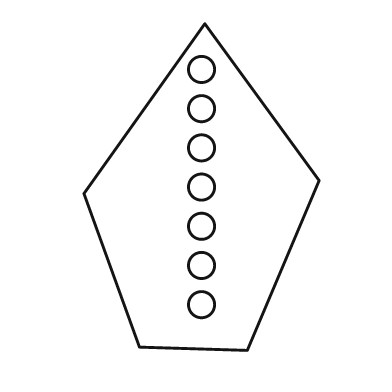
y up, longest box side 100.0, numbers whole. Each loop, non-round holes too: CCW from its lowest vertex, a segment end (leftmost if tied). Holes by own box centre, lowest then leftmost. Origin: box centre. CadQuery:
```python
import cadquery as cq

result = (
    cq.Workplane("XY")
    .moveTo(14.0, -50.0)
    .lineTo(36.0, 2.0)
    .lineTo(1.0, 50.0)
    .lineTo(-36.0, -2.0)
    .lineTo(-19.0, -49.0)
    .close()
    .moveTo(0.0, -36.0)
    .circle(4.0)
    .moveTo(0.0, -24.0)
    .circle(4.0)
    .moveTo(0.0, -12.0)
    .circle(4.0)
    .moveTo(0.0, 0.0)
    .circle(4.0)
    .moveTo(0.0, 12.0)
    .circle(4.0)
    .moveTo(0.0, 24.0)
    .circle(4.0)
    .moveTo(0.0, 36.0)
    .circle(4.0)
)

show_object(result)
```